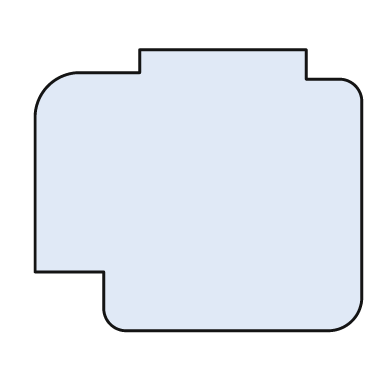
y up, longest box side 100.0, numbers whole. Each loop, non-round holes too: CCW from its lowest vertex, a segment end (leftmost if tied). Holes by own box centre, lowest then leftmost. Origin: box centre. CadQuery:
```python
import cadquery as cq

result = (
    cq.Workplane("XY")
    .moveTo(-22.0, -43.0)
    .lineTo(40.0, -43.0)
    .threePointArc((47.0, -40.0), (50.0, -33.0))
    .lineTo(50.0, 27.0)
    .threePointArc((48.0, 32.0), (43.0, 34.0))
    .lineTo(33.0, 34.0)
    .lineTo(33.0, 43.0)
    .lineTo(-18.0, 43.0)
    .lineTo(-18.0, 36.0)
    .lineTo(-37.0, 36.0)
    .threePointArc((-46.0, 32.0), (-50.0, 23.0))
    .lineTo(-50.0, -25.0)
    .lineTo(-29.0, -25.0)
    .lineTo(-29.0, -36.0)
    .threePointArc((-27.0, -41.0), (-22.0, -43.0))
    .close()
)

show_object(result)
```